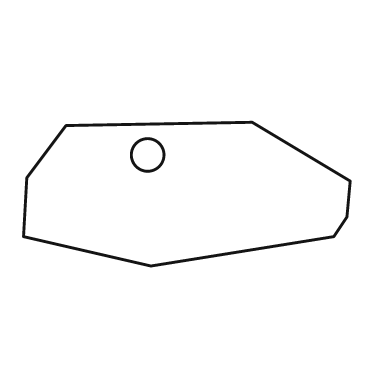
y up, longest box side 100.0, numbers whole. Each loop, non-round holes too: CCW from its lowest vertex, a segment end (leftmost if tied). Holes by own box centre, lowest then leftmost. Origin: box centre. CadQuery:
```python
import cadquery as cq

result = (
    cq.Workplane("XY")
    .moveTo(-11.0, -22.0)
    .lineTo(45.0, -13.0)
    .lineTo(49.0, -7.0)
    .lineTo(50.0, 4.0)
    .lineTo(20.0, 22.0)
    .lineTo(-37.0, 21.0)
    .lineTo(-49.0, 5.0)
    .lineTo(-50.0, -13.0)
    .close()
    .moveTo(-12.0, 12.0)
    .circle(5.0)
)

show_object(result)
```